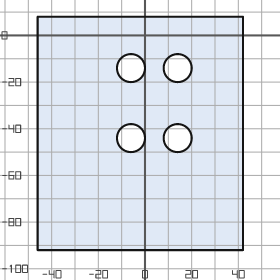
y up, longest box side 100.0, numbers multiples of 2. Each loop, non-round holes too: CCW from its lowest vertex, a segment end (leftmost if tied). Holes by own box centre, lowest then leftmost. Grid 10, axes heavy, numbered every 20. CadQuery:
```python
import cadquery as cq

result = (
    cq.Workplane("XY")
    .moveTo(-46.0, -92.0)
    .lineTo(42.0, -92.0)
    .lineTo(42.0, 8.0)
    .lineTo(-46.0, 8.0)
    .close()
    .moveTo(-6.0, -44.0)
    .circle(6.0)
    .moveTo(14.0, -44.0)
    .circle(6.0)
    .moveTo(-6.0, -14.0)
    .circle(6.0)
    .moveTo(14.0, -14.0)
    .circle(6.0)
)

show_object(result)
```